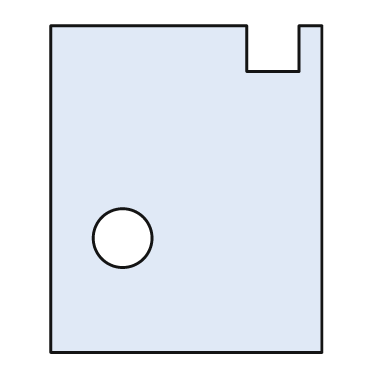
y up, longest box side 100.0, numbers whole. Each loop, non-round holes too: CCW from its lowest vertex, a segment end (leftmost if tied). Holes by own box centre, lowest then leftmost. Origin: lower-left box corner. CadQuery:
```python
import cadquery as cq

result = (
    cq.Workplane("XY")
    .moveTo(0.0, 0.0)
    .lineTo(83.0, 0.0)
    .lineTo(83.0, 100.0)
    .lineTo(76.0, 100.0)
    .lineTo(76.0, 86.0)
    .lineTo(60.0, 86.0)
    .lineTo(60.0, 100.0)
    .lineTo(0.0, 100.0)
    .close()
    .moveTo(22.0, 35.0)
    .circle(9.0)
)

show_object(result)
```